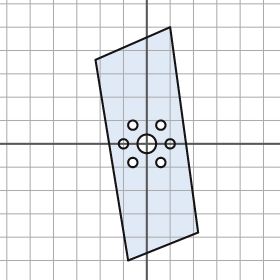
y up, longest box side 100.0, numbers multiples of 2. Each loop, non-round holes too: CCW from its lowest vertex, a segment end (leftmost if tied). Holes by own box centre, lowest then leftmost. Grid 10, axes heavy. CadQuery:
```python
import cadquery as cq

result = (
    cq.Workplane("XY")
    .moveTo(-8.0, -50.0)
    .lineTo(22.0, -38.0)
    .lineTo(10.0, 50.0)
    .lineTo(-22.0, 36.0)
    .close()
    .moveTo(-6.0, -8.0)
    .circle(2.0)
    .moveTo(6.0, -8.0)
    .circle(2.0)
    .moveTo(-10.0, 0.0)
    .circle(2.0)
    .moveTo(0.0, 0.0)
    .circle(4.0)
    .moveTo(10.0, 0.0)
    .circle(2.0)
    .moveTo(-6.0, 8.0)
    .circle(2.0)
    .moveTo(6.0, 8.0)
    .circle(2.0)
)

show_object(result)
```